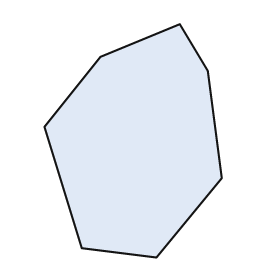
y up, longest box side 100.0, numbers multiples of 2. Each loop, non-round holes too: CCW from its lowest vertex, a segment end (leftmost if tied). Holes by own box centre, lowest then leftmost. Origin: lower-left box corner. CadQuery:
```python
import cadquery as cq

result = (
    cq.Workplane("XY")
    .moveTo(48.0, 0.0)
    .lineTo(76.0, 34.0)
    .lineTo(70.0, 80.0)
    .lineTo(58.0, 100.0)
    .lineTo(24.0, 86.0)
    .lineTo(0.0, 56.0)
    .lineTo(16.0, 4.0)
    .close()
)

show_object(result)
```